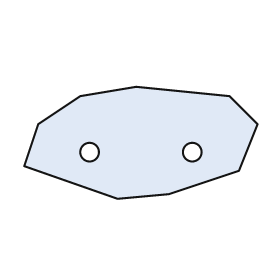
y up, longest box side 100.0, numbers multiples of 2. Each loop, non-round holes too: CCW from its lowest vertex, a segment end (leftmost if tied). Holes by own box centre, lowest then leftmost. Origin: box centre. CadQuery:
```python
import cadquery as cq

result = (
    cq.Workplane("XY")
    .moveTo(-10.0, -24.0)
    .lineTo(12.0, -22.0)
    .lineTo(42.0, -12.0)
    .lineTo(50.0, 8.0)
    .lineTo(38.0, 20.0)
    .lineTo(-2.0, 24.0)
    .lineTo(-26.0, 20.0)
    .lineTo(-44.0, 8.0)
    .lineTo(-50.0, -10.0)
    .close()
    .moveTo(-22.0, -4.0)
    .circle(4.0)
    .moveTo(22.0, -4.0)
    .circle(4.0)
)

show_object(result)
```